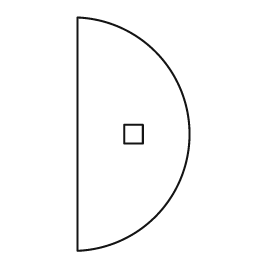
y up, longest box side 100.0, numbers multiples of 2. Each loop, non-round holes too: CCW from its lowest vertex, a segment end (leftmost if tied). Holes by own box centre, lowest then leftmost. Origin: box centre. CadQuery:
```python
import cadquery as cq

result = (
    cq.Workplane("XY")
    .moveTo(-24.0, -50.0)
    .threePointArc((24.0, 0.0), (-24.0, 50.0))
    .close()
    .moveTo(-4.0, -4.0)
    .lineTo(4.0, -4.0)
    .lineTo(4.0, 4.0)
    .lineTo(-4.0, 4.0)
    .close()
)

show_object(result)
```